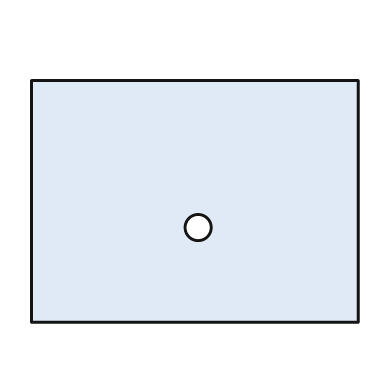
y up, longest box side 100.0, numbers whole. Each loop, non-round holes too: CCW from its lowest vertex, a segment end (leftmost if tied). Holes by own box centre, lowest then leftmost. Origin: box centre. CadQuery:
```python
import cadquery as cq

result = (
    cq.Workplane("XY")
    .moveTo(-50.0, -37.0)
    .lineTo(50.0, -37.0)
    .lineTo(50.0, 37.0)
    .lineTo(-50.0, 37.0)
    .close()
    .moveTo(1.0, -8.0)
    .circle(4.0)
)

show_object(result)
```